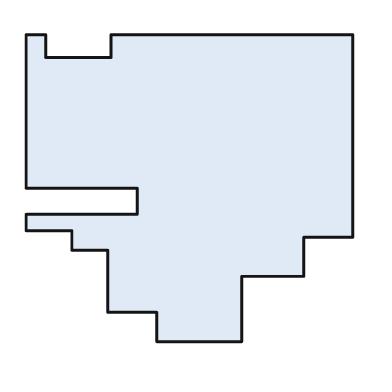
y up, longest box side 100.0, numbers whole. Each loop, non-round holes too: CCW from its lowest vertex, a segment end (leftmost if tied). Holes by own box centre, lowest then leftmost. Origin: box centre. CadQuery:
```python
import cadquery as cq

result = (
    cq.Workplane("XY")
    .moveTo(-10.0, -47.0)
    .lineTo(16.0, -47.0)
    .lineTo(16.0, -27.0)
    .lineTo(35.0, -27.0)
    .lineTo(35.0, -15.0)
    .lineTo(50.0, -15.0)
    .lineTo(50.0, 47.0)
    .lineTo(-24.0, 47.0)
    .lineTo(-24.0, 40.0)
    .lineTo(-44.0, 40.0)
    .lineTo(-44.0, 47.0)
    .lineTo(-50.0, 47.0)
    .lineTo(-50.0, 0.0)
    .lineTo(-16.0, 0.0)
    .lineTo(-16.0, -8.0)
    .lineTo(-50.0, -8.0)
    .lineTo(-50.0, -13.0)
    .lineTo(-36.0, -13.0)
    .lineTo(-36.0, -19.0)
    .lineTo(-25.0, -19.0)
    .lineTo(-25.0, -38.0)
    .lineTo(-10.0, -38.0)
    .close()
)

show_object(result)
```